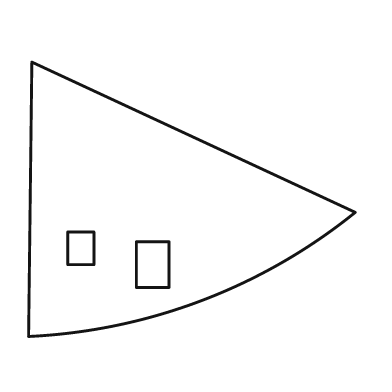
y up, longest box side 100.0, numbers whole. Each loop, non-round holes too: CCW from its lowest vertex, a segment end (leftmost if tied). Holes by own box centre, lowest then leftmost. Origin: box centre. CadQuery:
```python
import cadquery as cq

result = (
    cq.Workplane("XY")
    .moveTo(-50.0, -42.0)
    .threePointArc((3.0, -31.0), (50.0, -4.0))
    .lineTo(-49.0, 42.0)
    .close()
    .moveTo(-17.0, -27.0)
    .lineTo(-7.0, -27.0)
    .lineTo(-7.0, -13.0)
    .lineTo(-17.0, -13.0)
    .close()
    .moveTo(-38.0, -20.0)
    .lineTo(-30.0, -20.0)
    .lineTo(-30.0, -10.0)
    .lineTo(-38.0, -10.0)
    .close()
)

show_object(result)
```